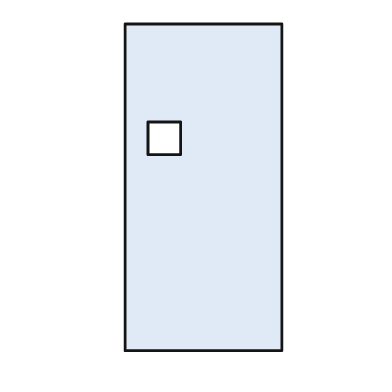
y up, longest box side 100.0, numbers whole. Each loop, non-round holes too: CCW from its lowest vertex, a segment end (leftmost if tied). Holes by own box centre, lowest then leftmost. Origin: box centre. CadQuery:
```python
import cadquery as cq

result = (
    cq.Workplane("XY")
    .moveTo(-24.0, -50.0)
    .lineTo(24.0, -50.0)
    .lineTo(24.0, 50.0)
    .lineTo(-24.0, 50.0)
    .close()
    .moveTo(-17.0, 10.0)
    .lineTo(-7.0, 10.0)
    .lineTo(-7.0, 20.0)
    .lineTo(-17.0, 20.0)
    .close()
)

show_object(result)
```